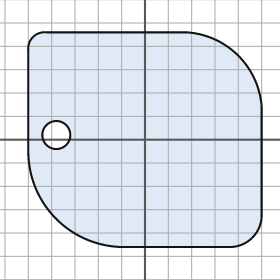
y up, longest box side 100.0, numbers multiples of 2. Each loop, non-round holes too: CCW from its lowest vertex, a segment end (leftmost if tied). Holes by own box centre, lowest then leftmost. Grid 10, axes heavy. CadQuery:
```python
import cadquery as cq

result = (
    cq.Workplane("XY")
    .moveTo(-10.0, -46.0)
    .lineTo(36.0, -46.0)
    .threePointArc((46.0, -42.0), (50.0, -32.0))
    .lineTo(50.0, 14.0)
    .threePointArc((40.0, 36.0), (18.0, 46.0))
    .lineTo(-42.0, 46.0)
    .threePointArc((-48.0, 44.0), (-50.0, 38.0))
    .lineTo(-50.0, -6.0)
    .threePointArc((-38.0, -34.0), (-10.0, -46.0))
    .close()
    .moveTo(-38.0, 2.0)
    .circle(6.0)
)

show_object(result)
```